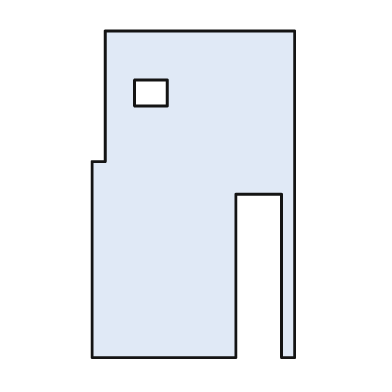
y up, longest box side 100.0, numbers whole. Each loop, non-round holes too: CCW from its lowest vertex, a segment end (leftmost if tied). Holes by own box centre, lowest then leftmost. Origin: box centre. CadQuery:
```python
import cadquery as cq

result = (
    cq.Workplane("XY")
    .moveTo(-31.0, -50.0)
    .lineTo(13.0, -50.0)
    .lineTo(13.0, 0.0)
    .lineTo(27.0, 0.0)
    .lineTo(27.0, -50.0)
    .lineTo(31.0, -50.0)
    .lineTo(31.0, 50.0)
    .lineTo(-27.0, 50.0)
    .lineTo(-27.0, 10.0)
    .lineTo(-31.0, 10.0)
    .close()
    .moveTo(-18.0, 27.0)
    .lineTo(-8.0, 27.0)
    .lineTo(-8.0, 35.0)
    .lineTo(-18.0, 35.0)
    .close()
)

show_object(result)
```